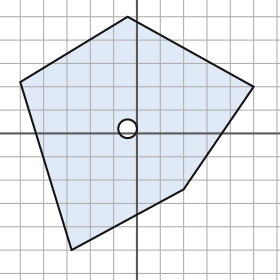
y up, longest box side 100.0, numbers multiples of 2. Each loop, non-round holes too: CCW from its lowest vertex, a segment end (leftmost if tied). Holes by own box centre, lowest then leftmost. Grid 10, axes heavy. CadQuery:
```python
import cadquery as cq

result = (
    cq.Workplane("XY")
    .moveTo(-28.0, -50.0)
    .lineTo(20.0, -24.0)
    .lineTo(50.0, 20.0)
    .lineTo(-4.0, 50.0)
    .lineTo(-50.0, 22.0)
    .close()
    .moveTo(-4.0, 2.0)
    .circle(4.0)
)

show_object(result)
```